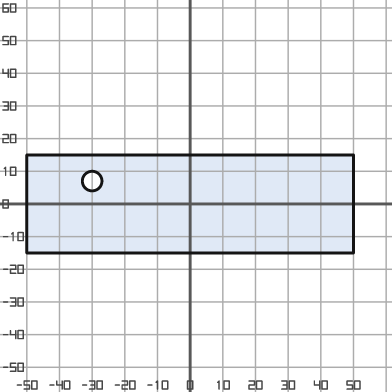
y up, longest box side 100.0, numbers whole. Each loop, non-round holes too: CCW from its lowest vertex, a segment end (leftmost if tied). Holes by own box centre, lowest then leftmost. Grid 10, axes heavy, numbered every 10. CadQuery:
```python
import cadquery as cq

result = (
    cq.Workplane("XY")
    .moveTo(-50.0, -15.0)
    .lineTo(50.0, -15.0)
    .lineTo(50.0, 15.0)
    .lineTo(-50.0, 15.0)
    .close()
    .moveTo(-30.0, 7.0)
    .circle(3.0)
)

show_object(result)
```